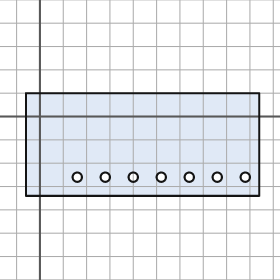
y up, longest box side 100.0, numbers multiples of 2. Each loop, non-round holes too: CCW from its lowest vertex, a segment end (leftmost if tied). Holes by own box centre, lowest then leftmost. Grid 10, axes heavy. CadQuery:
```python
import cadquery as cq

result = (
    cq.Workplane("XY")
    .moveTo(-6.0, -34.0)
    .lineTo(94.0, -34.0)
    .lineTo(94.0, 10.0)
    .lineTo(-6.0, 10.0)
    .close()
    .moveTo(16.0, -26.0)
    .circle(2.0)
    .moveTo(28.0, -26.0)
    .circle(2.0)
    .moveTo(40.0, -26.0)
    .circle(2.0)
    .moveTo(52.0, -26.0)
    .circle(2.0)
    .moveTo(64.0, -26.0)
    .circle(2.0)
    .moveTo(76.0, -26.0)
    .circle(2.0)
    .moveTo(88.0, -26.0)
    .circle(2.0)
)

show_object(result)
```